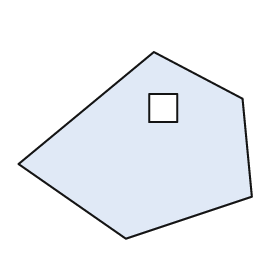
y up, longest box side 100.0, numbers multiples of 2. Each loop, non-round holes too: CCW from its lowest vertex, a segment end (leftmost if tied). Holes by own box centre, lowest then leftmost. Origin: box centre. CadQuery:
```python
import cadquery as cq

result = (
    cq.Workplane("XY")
    .moveTo(-4.0, -40.0)
    .lineTo(50.0, -22.0)
    .lineTo(46.0, 20.0)
    .lineTo(8.0, 40.0)
    .lineTo(-50.0, -8.0)
    .close()
    .moveTo(6.0, 10.0)
    .lineTo(18.0, 10.0)
    .lineTo(18.0, 22.0)
    .lineTo(6.0, 22.0)
    .close()
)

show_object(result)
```